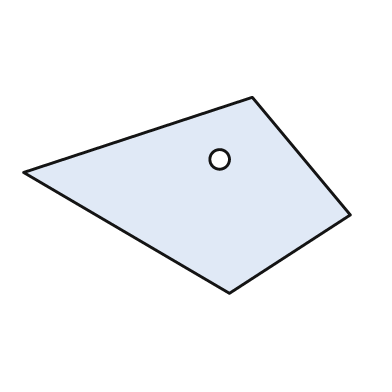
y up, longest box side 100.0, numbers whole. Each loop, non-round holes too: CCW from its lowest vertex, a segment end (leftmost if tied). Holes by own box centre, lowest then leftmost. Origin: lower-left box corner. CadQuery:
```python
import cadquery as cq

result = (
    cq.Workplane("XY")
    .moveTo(63.0, 0.0)
    .lineTo(100.0, 24.0)
    .lineTo(70.0, 60.0)
    .lineTo(0.0, 37.0)
    .close()
    .moveTo(60.0, 41.0)
    .circle(3.0)
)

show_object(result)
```